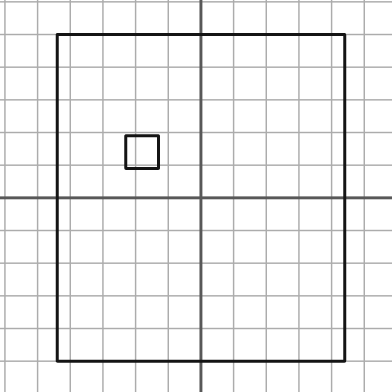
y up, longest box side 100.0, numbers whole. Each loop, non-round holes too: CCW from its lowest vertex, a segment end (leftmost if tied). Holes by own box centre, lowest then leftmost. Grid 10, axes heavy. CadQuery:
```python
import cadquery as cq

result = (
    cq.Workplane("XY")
    .moveTo(-44.0, -50.0)
    .lineTo(44.0, -50.0)
    .lineTo(44.0, 50.0)
    .lineTo(-44.0, 50.0)
    .close()
    .moveTo(-23.0, 9.0)
    .lineTo(-13.0, 9.0)
    .lineTo(-13.0, 19.0)
    .lineTo(-23.0, 19.0)
    .close()
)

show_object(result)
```